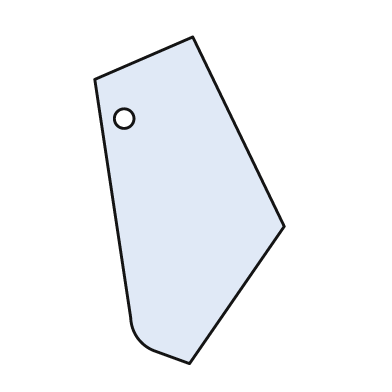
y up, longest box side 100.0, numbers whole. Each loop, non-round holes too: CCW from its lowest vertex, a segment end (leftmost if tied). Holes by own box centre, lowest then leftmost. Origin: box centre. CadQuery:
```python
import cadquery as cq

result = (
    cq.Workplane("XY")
    .moveTo(0.0, -50.0)
    .lineTo(29.0, -8.0)
    .lineTo(1.0, 50.0)
    .lineTo(-29.0, 37.0)
    .lineTo(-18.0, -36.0)
    .threePointArc((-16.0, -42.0), (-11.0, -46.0))
    .close()
    .moveTo(-20.0, 25.0)
    .circle(3.0)
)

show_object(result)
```